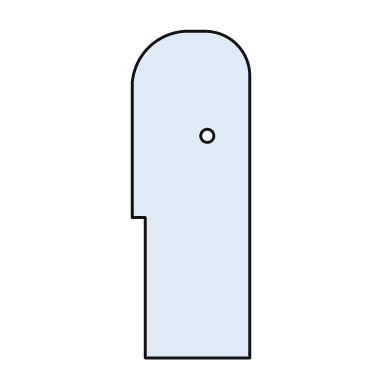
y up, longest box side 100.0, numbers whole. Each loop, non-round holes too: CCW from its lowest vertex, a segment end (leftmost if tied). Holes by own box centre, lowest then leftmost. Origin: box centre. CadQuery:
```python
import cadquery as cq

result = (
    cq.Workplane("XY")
    .moveTo(-14.0, -50.0)
    .lineTo(18.0, -50.0)
    .lineTo(18.0, 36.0)
    .threePointArc((14.0, 46.0), (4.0, 50.0))
    .lineTo(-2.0, 50.0)
    .threePointArc((-13.0, 45.0), (-18.0, 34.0))
    .lineTo(-18.0, -7.0)
    .lineTo(-14.0, -7.0)
    .close()
    .moveTo(5.0, 18.0)
    .circle(2.0)
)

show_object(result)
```